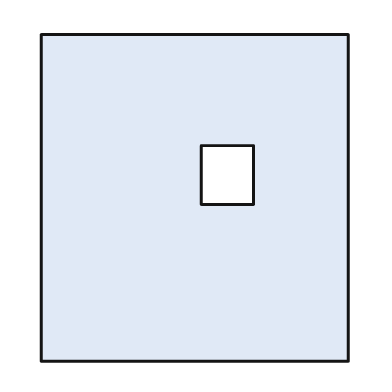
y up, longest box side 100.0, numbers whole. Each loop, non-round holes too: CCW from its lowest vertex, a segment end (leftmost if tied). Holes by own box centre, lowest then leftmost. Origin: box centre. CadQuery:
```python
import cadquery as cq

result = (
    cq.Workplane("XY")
    .moveTo(-47.0, -50.0)
    .lineTo(47.0, -50.0)
    .lineTo(47.0, 50.0)
    .lineTo(-47.0, 50.0)
    .close()
    .moveTo(2.0, -2.0)
    .lineTo(18.0, -2.0)
    .lineTo(18.0, 16.0)
    .lineTo(2.0, 16.0)
    .close()
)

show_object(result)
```